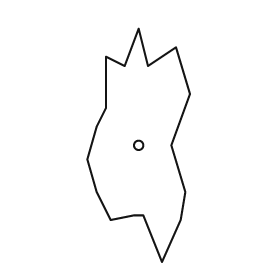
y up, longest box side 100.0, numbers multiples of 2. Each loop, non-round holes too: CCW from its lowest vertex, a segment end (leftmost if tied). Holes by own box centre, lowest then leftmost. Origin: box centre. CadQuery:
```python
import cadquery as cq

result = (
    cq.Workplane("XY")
    .moveTo(10.0, -50.0)
    .lineTo(18.0, -32.0)
    .lineTo(20.0, -20.0)
    .lineTo(14.0, 0.0)
    .lineTo(22.0, 22.0)
    .lineTo(16.0, 42.0)
    .lineTo(4.0, 34.0)
    .lineTo(0.0, 50.0)
    .lineTo(-6.0, 34.0)
    .lineTo(-14.0, 38.0)
    .lineTo(-14.0, 16.0)
    .lineTo(-18.0, 8.0)
    .lineTo(-22.0, -6.0)
    .lineTo(-18.0, -20.0)
    .lineTo(-12.0, -32.0)
    .lineTo(-2.0, -30.0)
    .lineTo(2.0, -30.0)
    .close()
    .moveTo(0.0, 0.0)
    .circle(2.0)
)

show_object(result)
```